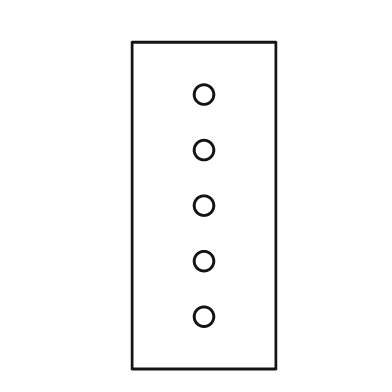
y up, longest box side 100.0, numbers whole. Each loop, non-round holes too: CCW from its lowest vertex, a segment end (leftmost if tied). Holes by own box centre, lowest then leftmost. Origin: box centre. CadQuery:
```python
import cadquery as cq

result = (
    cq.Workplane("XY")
    .moveTo(-22.0, -50.0)
    .lineTo(22.0, -50.0)
    .lineTo(22.0, 50.0)
    .lineTo(-22.0, 50.0)
    .close()
    .moveTo(0.0, -34.0)
    .circle(3.0)
    .moveTo(0.0, -17.0)
    .circle(3.0)
    .moveTo(0.0, 0.0)
    .circle(3.0)
    .moveTo(0.0, 17.0)
    .circle(3.0)
    .moveTo(0.0, 34.0)
    .circle(3.0)
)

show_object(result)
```